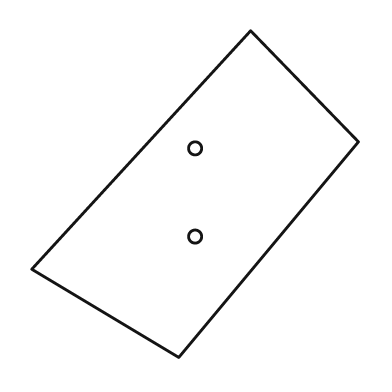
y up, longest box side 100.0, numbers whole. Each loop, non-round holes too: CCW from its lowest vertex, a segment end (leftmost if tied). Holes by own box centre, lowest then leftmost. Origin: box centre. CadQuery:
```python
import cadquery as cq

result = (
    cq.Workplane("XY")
    .moveTo(-5.0, -50.0)
    .lineTo(50.0, 16.0)
    .lineTo(17.0, 50.0)
    .lineTo(-50.0, -23.0)
    .close()
    .moveTo(0.0, -13.0)
    .circle(2.0)
    .moveTo(0.0, 14.0)
    .circle(2.0)
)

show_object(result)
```